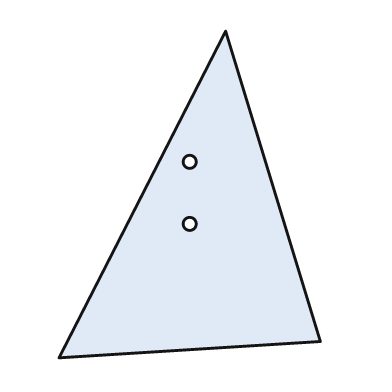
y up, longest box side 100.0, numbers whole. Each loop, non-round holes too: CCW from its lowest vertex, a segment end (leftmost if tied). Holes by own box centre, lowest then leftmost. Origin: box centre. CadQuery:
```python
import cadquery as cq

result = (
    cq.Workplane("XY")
    .moveTo(-40.0, -50.0)
    .lineTo(40.0, -45.0)
    .lineTo(11.0, 50.0)
    .close()
    .moveTo(0.0, -9.0)
    .circle(2.0)
    .moveTo(0.0, 10.0)
    .circle(2.0)
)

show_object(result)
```